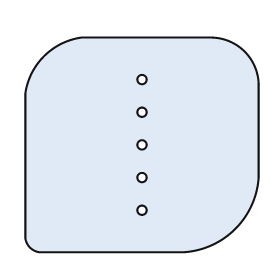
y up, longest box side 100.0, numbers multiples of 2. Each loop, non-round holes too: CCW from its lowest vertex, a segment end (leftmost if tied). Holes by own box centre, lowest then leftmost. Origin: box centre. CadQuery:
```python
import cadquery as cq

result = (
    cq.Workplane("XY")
    .moveTo(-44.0, -46.0)
    .lineTo(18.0, -46.0)
    .threePointArc((40.0, -36.0), (50.0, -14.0))
    .lineTo(50.0, 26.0)
    .threePointArc((44.0, 40.0), (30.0, 46.0))
    .lineTo(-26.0, 46.0)
    .threePointArc((-42.0, 38.0), (-50.0, 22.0))
    .lineTo(-50.0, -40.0)
    .threePointArc((-48.0, -44.0), (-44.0, -46.0))
    .close()
    .moveTo(0.0, -28.0)
    .circle(2.0)
    .moveTo(0.0, -14.0)
    .circle(2.0)
    .moveTo(0.0, 0.0)
    .circle(2.0)
    .moveTo(0.0, 14.0)
    .circle(2.0)
    .moveTo(0.0, 28.0)
    .circle(2.0)
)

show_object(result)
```